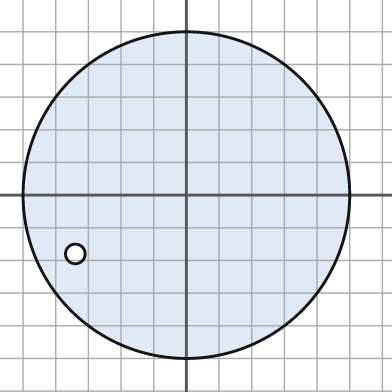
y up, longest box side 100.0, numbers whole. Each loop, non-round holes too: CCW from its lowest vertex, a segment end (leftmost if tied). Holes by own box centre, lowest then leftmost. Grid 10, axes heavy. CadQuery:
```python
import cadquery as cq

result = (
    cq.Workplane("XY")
    .moveTo(0.0, 0.0)
    .circle(50.0)
    .moveTo(-34.0, -18.0)
    .circle(3.0)
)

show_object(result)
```